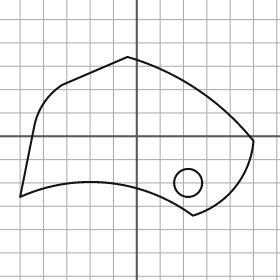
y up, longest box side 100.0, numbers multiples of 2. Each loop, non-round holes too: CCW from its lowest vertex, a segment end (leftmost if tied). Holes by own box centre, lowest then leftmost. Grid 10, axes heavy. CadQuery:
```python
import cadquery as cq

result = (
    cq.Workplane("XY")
    .moveTo(24.0, -34.0)
    .threePointArc((42.0, -22.0), (50.0, -2.0))
    .threePointArc((26.0, 20.0), (-4.0, 34.0))
    .lineTo(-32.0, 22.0)
    .threePointArc((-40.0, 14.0), (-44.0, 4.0))
    .lineTo(-50.0, -26.0)
    .threePointArc((-12.0, -20.0), (24.0, -34.0))
    .close()
    .moveTo(22.0, -20.0)
    .circle(6.0)
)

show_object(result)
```